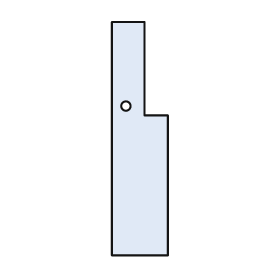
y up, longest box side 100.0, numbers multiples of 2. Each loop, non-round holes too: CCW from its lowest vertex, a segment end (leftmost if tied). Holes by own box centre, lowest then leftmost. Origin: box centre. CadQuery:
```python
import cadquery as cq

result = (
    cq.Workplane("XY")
    .moveTo(-12.0, -50.0)
    .lineTo(12.0, -50.0)
    .lineTo(12.0, 10.0)
    .lineTo(2.0, 10.0)
    .lineTo(2.0, 50.0)
    .lineTo(-12.0, 50.0)
    .close()
    .moveTo(-6.0, 14.0)
    .circle(2.0)
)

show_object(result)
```